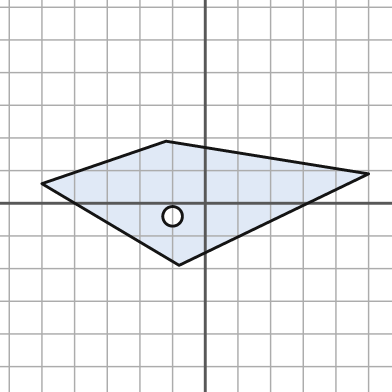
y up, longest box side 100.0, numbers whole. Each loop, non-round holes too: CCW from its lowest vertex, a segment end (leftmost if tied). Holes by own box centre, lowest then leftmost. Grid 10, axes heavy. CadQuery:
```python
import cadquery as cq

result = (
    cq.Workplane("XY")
    .moveTo(-8.0, -19.0)
    .lineTo(50.0, 9.0)
    .lineTo(-12.0, 19.0)
    .lineTo(-50.0, 6.0)
    .close()
    .moveTo(-10.0, -4.0)
    .circle(3.0)
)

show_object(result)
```